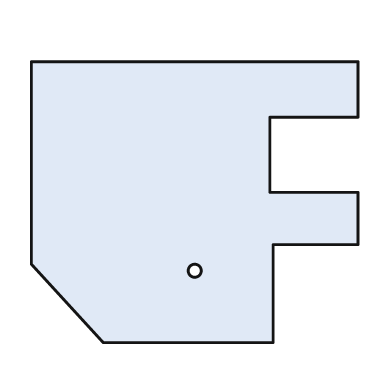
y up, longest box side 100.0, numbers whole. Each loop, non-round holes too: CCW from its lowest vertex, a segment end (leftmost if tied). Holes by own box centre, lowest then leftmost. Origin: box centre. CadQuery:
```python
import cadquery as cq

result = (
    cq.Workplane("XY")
    .moveTo(-28.0, -43.0)
    .lineTo(24.0, -43.0)
    .lineTo(24.0, -13.0)
    .lineTo(50.0, -13.0)
    .lineTo(50.0, 3.0)
    .lineTo(23.0, 3.0)
    .lineTo(23.0, 26.0)
    .lineTo(50.0, 26.0)
    .lineTo(50.0, 43.0)
    .lineTo(-50.0, 43.0)
    .lineTo(-50.0, -19.0)
    .close()
    .moveTo(0.0, -21.0)
    .circle(2.0)
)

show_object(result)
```